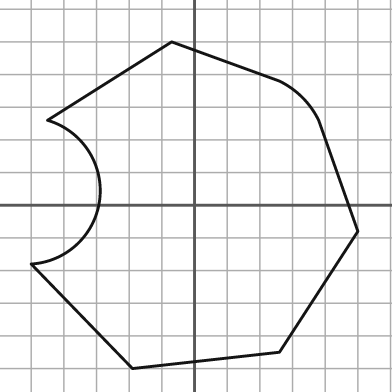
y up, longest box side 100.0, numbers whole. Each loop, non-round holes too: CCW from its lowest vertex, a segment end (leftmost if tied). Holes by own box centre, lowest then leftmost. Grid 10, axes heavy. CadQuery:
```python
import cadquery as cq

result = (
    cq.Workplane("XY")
    .moveTo(-19.0, -50.0)
    .lineTo(26.0, -45.0)
    .lineTo(50.0, -8.0)
    .lineTo(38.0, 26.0)
    .threePointArc((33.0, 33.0), (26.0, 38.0))
    .lineTo(-7.0, 50.0)
    .lineTo(-45.0, 26.0)
    .threePointArc((-29.0, 2.0), (-50.0, -18.0))
    .close()
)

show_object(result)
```